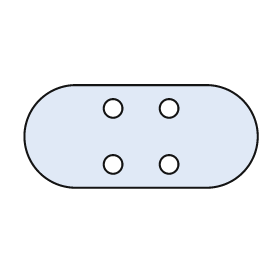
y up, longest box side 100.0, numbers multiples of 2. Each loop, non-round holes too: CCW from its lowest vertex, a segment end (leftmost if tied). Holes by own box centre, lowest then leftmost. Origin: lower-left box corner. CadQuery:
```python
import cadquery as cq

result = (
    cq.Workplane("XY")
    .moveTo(22.0, 0.0)
    .lineTo(78.0, 0.0)
    .threePointArc((100.0, 22.0), (78.0, 44.0))
    .lineTo(22.0, 44.0)
    .threePointArc((0.0, 22.0), (22.0, 0.0))
    .close()
    .moveTo(38.0, 10.0)
    .circle(4.0)
    .moveTo(62.0, 10.0)
    .circle(4.0)
    .moveTo(38.0, 34.0)
    .circle(4.0)
    .moveTo(62.0, 34.0)
    .circle(4.0)
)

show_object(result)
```